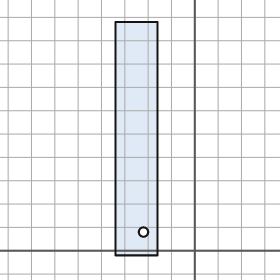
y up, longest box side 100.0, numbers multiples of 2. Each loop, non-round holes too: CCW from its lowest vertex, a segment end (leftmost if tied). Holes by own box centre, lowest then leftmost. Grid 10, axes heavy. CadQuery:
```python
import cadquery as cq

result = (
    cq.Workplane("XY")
    .moveTo(-34.0, -2.0)
    .lineTo(-16.0, -2.0)
    .lineTo(-16.0, 98.0)
    .lineTo(-34.0, 98.0)
    .close()
    .moveTo(-22.0, 8.0)
    .circle(2.0)
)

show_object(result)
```